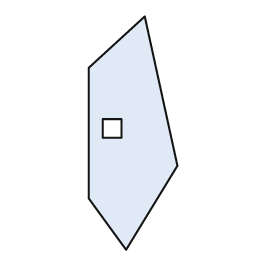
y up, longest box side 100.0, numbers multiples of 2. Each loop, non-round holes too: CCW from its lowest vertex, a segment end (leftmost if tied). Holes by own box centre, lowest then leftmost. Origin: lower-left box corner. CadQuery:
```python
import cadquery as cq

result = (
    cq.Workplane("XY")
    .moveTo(16.0, 0.0)
    .lineTo(38.0, 36.0)
    .lineTo(24.0, 100.0)
    .lineTo(0.0, 78.0)
    .lineTo(0.0, 22.0)
    .close()
    .moveTo(6.0, 48.0)
    .lineTo(14.0, 48.0)
    .lineTo(14.0, 56.0)
    .lineTo(6.0, 56.0)
    .close()
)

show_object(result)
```